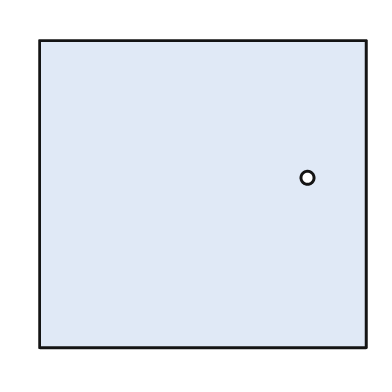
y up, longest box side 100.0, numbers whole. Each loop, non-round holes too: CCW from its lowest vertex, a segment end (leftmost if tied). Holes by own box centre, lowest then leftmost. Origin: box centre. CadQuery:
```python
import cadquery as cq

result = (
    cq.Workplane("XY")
    .moveTo(-50.0, -47.0)
    .lineTo(50.0, -47.0)
    .lineTo(50.0, 47.0)
    .lineTo(-50.0, 47.0)
    .close()
    .moveTo(32.0, 5.0)
    .circle(2.0)
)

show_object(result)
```